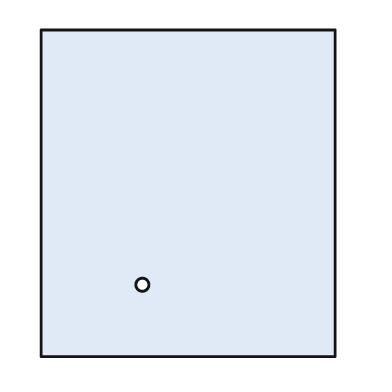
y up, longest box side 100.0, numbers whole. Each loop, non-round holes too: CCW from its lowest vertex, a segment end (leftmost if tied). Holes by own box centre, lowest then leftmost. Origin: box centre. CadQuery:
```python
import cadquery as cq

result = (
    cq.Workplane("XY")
    .moveTo(-45.0, -50.0)
    .lineTo(45.0, -50.0)
    .lineTo(45.0, 50.0)
    .lineTo(-45.0, 50.0)
    .close()
    .moveTo(-14.0, -28.0)
    .circle(2.0)
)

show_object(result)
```